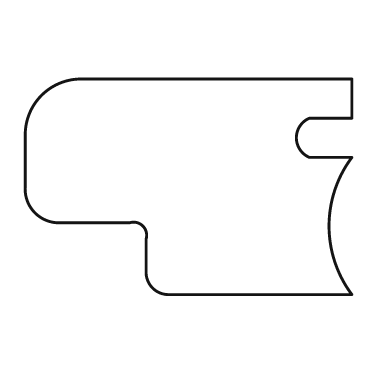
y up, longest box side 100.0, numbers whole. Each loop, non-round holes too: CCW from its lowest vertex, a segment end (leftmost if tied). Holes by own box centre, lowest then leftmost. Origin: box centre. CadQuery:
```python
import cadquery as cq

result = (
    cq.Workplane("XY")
    .moveTo(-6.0, -33.0)
    .lineTo(50.0, -33.0)
    .threePointArc((43.0, -12.0), (50.0, 9.0))
    .lineTo(37.0, 9.0)
    .threePointArc((33.0, 15.0), (37.0, 21.0))
    .lineTo(50.0, 21.0)
    .lineTo(50.0, 33.0)
    .lineTo(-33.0, 33.0)
    .threePointArc((-45.0, 28.0), (-50.0, 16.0))
    .lineTo(-50.0, 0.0)
    .threePointArc((-47.0, -8.0), (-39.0, -11.0))
    .lineTo(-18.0, -11.0)
    .threePointArc((-14.0, -12.0), (-13.0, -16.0))
    .lineTo(-13.0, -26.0)
    .threePointArc((-11.0, -31.0), (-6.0, -33.0))
    .close()
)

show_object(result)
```